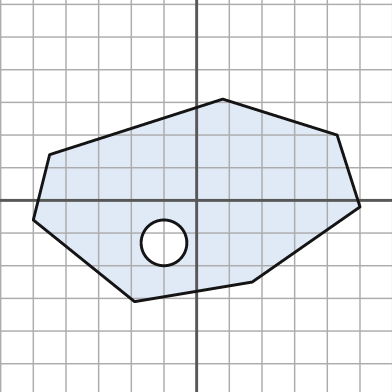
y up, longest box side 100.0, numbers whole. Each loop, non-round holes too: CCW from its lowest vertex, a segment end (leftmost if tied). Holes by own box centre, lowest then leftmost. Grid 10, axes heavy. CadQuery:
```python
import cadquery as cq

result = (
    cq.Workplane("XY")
    .moveTo(-19.0, -31.0)
    .lineTo(17.0, -25.0)
    .lineTo(50.0, -2.0)
    .lineTo(43.0, 20.0)
    .lineTo(8.0, 31.0)
    .lineTo(-45.0, 14.0)
    .lineTo(-50.0, -6.0)
    .close()
    .moveTo(-10.0, -13.0)
    .circle(7.0)
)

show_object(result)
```